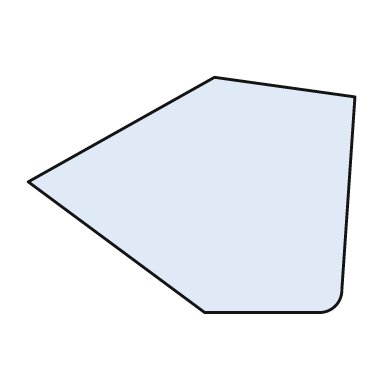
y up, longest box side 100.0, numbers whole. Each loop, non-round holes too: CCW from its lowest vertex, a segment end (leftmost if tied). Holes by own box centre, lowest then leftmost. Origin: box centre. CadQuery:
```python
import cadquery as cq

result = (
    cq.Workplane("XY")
    .moveTo(4.0, -36.0)
    .lineTo(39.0, -36.0)
    .threePointArc((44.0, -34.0), (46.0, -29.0))
    .lineTo(50.0, 30.0)
    .lineTo(7.0, 36.0)
    .lineTo(-50.0, 4.0)
    .close()
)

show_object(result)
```